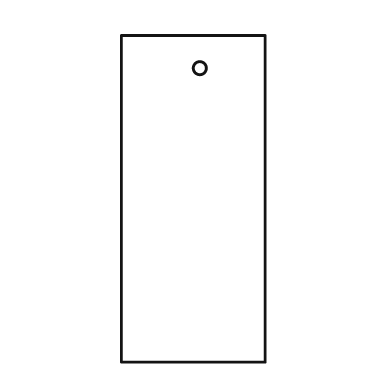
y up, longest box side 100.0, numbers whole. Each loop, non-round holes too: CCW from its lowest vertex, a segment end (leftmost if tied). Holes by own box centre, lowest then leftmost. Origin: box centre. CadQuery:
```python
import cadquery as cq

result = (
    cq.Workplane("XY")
    .moveTo(-22.0, -50.0)
    .lineTo(22.0, -50.0)
    .lineTo(22.0, 50.0)
    .lineTo(-22.0, 50.0)
    .close()
    .moveTo(2.0, 40.0)
    .circle(2.0)
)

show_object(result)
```